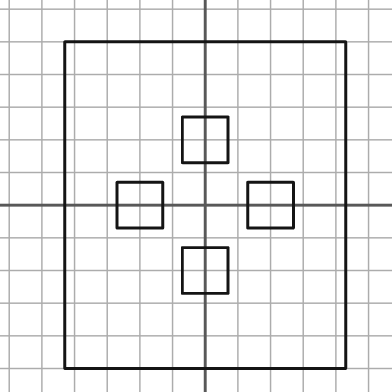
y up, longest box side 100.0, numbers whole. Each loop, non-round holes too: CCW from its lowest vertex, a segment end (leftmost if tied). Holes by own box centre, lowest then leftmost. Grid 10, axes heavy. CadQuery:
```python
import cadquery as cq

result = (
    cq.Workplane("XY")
    .moveTo(-43.0, -50.0)
    .lineTo(43.0, -50.0)
    .lineTo(43.0, 50.0)
    .lineTo(-43.0, 50.0)
    .close()
    .moveTo(-7.0, -27.0)
    .lineTo(7.0, -27.0)
    .lineTo(7.0, -13.0)
    .lineTo(-7.0, -13.0)
    .close()
    .moveTo(-27.0, -7.0)
    .lineTo(-13.0, -7.0)
    .lineTo(-13.0, 7.0)
    .lineTo(-27.0, 7.0)
    .close()
    .moveTo(13.0, -7.0)
    .lineTo(27.0, -7.0)
    .lineTo(27.0, 7.0)
    .lineTo(13.0, 7.0)
    .close()
    .moveTo(-7.0, 13.0)
    .lineTo(7.0, 13.0)
    .lineTo(7.0, 27.0)
    .lineTo(-7.0, 27.0)
    .close()
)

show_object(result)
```